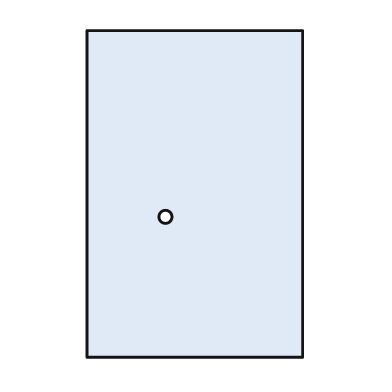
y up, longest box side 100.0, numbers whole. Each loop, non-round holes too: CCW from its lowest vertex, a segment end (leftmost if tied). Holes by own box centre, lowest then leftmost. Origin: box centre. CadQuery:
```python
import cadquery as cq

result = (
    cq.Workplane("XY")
    .moveTo(-33.0, -50.0)
    .lineTo(33.0, -50.0)
    .lineTo(33.0, 50.0)
    .lineTo(-33.0, 50.0)
    .close()
    .moveTo(-9.0, -7.0)
    .circle(2.0)
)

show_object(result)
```